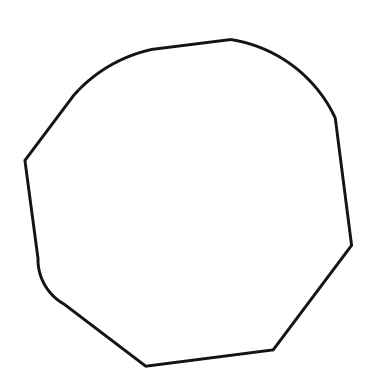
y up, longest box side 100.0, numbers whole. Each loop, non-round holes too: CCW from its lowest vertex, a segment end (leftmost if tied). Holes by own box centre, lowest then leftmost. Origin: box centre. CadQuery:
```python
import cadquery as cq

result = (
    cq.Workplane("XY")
    .moveTo(-13.0, -50.0)
    .lineTo(26.0, -45.0)
    .lineTo(50.0, -13.0)
    .lineTo(45.0, 26.0)
    .threePointArc((32.0, 42.0), (13.0, 50.0))
    .lineTo(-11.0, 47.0)
    .threePointArc((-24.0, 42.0), (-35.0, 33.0))
    .lineTo(-50.0, 13.0)
    .lineTo(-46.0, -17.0)
    .threePointArc((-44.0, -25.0), (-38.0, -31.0))
    .close()
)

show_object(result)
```